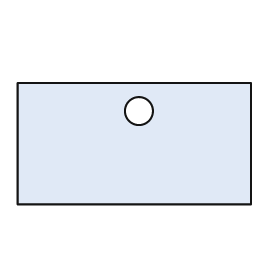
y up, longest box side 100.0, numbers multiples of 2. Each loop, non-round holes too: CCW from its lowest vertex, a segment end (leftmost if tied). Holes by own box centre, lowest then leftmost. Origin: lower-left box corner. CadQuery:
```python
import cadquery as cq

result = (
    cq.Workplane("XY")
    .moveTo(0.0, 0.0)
    .lineTo(100.0, 0.0)
    .lineTo(100.0, 52.0)
    .lineTo(0.0, 52.0)
    .close()
    .moveTo(52.0, 40.0)
    .circle(6.0)
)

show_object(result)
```